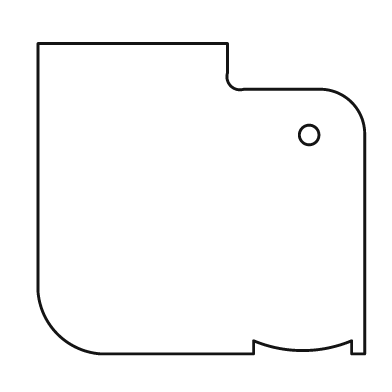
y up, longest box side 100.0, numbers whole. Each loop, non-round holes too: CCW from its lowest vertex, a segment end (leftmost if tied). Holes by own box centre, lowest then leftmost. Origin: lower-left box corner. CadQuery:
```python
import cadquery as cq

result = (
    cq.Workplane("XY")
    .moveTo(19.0, 0.0)
    .lineTo(66.0, 0.0)
    .lineTo(66.0, 4.0)
    .threePointArc((81.0, 1.0), (96.0, 4.0))
    .lineTo(96.0, 0.0)
    .lineTo(100.0, 0.0)
    .lineTo(100.0, 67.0)
    .threePointArc((96.0, 77.0), (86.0, 81.0))
    .lineTo(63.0, 81.0)
    .threePointArc((59.0, 82.0), (58.0, 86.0))
    .lineTo(58.0, 95.0)
    .lineTo(0.0, 95.0)
    .lineTo(0.0, 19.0)
    .threePointArc((6.0, 6.0), (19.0, 0.0))
    .close()
    .moveTo(83.0, 67.0)
    .circle(3.0)
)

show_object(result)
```